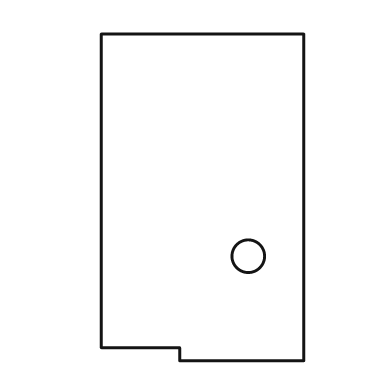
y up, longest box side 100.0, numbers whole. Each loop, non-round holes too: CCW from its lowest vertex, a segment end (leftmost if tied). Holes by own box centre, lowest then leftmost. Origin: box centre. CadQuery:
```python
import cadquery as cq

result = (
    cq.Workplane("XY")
    .moveTo(-7.0, -50.0)
    .lineTo(31.0, -50.0)
    .lineTo(31.0, 50.0)
    .lineTo(-31.0, 50.0)
    .lineTo(-31.0, -46.0)
    .lineTo(-7.0, -46.0)
    .close()
    .moveTo(14.0, -18.0)
    .circle(5.0)
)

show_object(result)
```